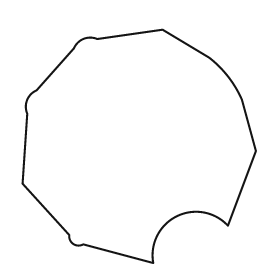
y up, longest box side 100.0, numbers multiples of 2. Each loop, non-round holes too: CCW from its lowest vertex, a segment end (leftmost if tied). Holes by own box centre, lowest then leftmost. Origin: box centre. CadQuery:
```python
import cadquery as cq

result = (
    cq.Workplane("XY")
    .moveTo(6.0, -50.0)
    .threePointArc((16.0, -30.0), (38.0, -34.0))
    .lineTo(50.0, -2.0)
    .lineTo(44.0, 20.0)
    .threePointArc((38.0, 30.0), (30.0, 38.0))
    .lineTo(10.0, 50.0)
    .lineTo(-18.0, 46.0)
    .threePointArc((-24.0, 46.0), (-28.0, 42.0))
    .lineTo(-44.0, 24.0)
    .threePointArc((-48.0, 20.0), (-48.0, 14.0))
    .lineTo(-50.0, -16.0)
    .lineTo(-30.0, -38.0)
    .threePointArc((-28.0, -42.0), (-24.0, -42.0))
    .close()
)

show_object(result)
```